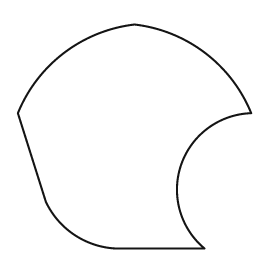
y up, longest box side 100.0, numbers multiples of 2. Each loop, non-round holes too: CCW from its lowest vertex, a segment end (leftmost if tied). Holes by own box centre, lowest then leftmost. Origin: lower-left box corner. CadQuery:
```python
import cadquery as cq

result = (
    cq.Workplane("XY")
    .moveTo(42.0, 0.0)
    .lineTo(80.0, 0.0)
    .threePointArc((70.0, 36.0), (100.0, 58.0))
    .threePointArc((80.0, 84.0), (50.0, 96.0))
    .threePointArc((20.0, 84.0), (0.0, 58.0))
    .lineTo(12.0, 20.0)
    .threePointArc((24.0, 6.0), (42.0, 0.0))
    .close()
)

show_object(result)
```